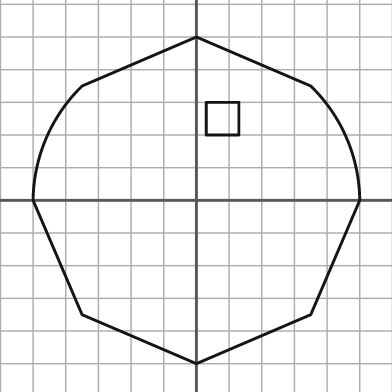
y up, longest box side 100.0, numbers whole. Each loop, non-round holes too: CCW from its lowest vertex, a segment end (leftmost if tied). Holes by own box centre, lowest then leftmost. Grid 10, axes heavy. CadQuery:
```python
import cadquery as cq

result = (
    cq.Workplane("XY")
    .moveTo(0.0, -50.0)
    .lineTo(35.0, -35.0)
    .lineTo(50.0, 0.0)
    .threePointArc((46.0, 19.0), (35.0, 35.0))
    .lineTo(0.0, 50.0)
    .lineTo(-35.0, 35.0)
    .threePointArc((-46.0, 19.0), (-50.0, 0.0))
    .lineTo(-35.0, -35.0)
    .close()
    .moveTo(3.0, 20.0)
    .lineTo(13.0, 20.0)
    .lineTo(13.0, 30.0)
    .lineTo(3.0, 30.0)
    .close()
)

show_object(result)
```